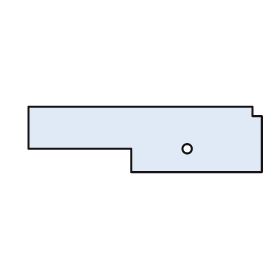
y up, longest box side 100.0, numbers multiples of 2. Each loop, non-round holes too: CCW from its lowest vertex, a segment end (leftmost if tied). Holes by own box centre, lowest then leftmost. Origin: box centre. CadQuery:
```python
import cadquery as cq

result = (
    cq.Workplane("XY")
    .moveTo(-6.0, -14.0)
    .lineTo(50.0, -14.0)
    .lineTo(50.0, 10.0)
    .lineTo(46.0, 10.0)
    .lineTo(46.0, 14.0)
    .lineTo(-50.0, 14.0)
    .lineTo(-50.0, -4.0)
    .lineTo(-6.0, -4.0)
    .close()
    .moveTo(18.0, -4.0)
    .circle(2.0)
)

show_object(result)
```